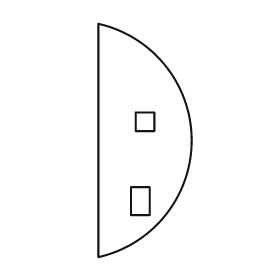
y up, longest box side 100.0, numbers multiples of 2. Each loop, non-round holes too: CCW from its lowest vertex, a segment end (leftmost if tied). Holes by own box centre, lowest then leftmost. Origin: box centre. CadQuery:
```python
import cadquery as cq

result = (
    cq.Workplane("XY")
    .moveTo(-20.0, -50.0)
    .threePointArc((20.0, 0.0), (-20.0, 50.0))
    .close()
    .moveTo(-6.0, -32.0)
    .lineTo(2.0, -32.0)
    .lineTo(2.0, -20.0)
    .lineTo(-6.0, -20.0)
    .close()
    .moveTo(-4.0, 4.0)
    .lineTo(4.0, 4.0)
    .lineTo(4.0, 12.0)
    .lineTo(-4.0, 12.0)
    .close()
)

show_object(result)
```